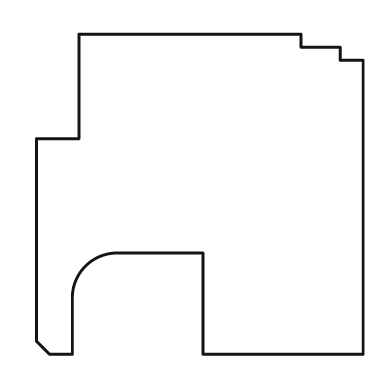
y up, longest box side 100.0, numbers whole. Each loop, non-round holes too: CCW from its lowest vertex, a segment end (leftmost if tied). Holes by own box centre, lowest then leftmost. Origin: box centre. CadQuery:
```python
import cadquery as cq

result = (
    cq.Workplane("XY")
    .moveTo(-46.0, -49.0)
    .lineTo(-39.0, -49.0)
    .lineTo(-39.0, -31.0)
    .threePointArc((-35.0, -22.0), (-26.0, -18.0))
    .lineTo(1.0, -18.0)
    .lineTo(1.0, -49.0)
    .lineTo(50.0, -49.0)
    .lineTo(50.0, 41.0)
    .lineTo(43.0, 41.0)
    .lineTo(43.0, 45.0)
    .lineTo(31.0, 45.0)
    .lineTo(31.0, 49.0)
    .lineTo(-37.0, 49.0)
    .lineTo(-37.0, 17.0)
    .lineTo(-50.0, 17.0)
    .lineTo(-50.0, -45.0)
    .close()
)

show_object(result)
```